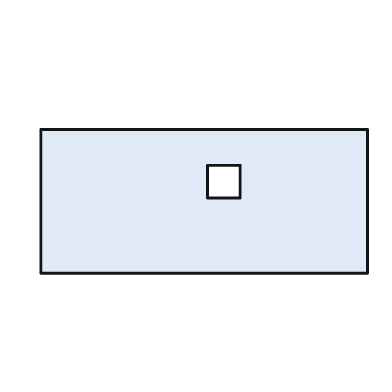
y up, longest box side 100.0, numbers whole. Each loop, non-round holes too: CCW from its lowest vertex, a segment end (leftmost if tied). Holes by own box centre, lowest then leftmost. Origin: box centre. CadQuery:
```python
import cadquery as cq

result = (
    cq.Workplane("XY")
    .moveTo(-50.0, -22.0)
    .lineTo(50.0, -22.0)
    .lineTo(50.0, 22.0)
    .lineTo(-50.0, 22.0)
    .close()
    .moveTo(1.0, 1.0)
    .lineTo(11.0, 1.0)
    .lineTo(11.0, 11.0)
    .lineTo(1.0, 11.0)
    .close()
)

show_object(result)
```